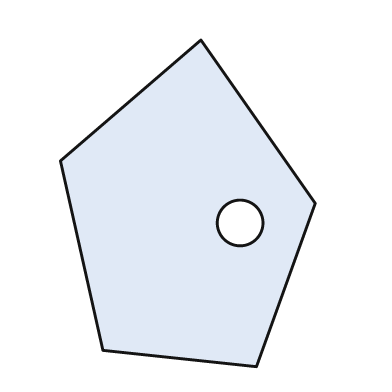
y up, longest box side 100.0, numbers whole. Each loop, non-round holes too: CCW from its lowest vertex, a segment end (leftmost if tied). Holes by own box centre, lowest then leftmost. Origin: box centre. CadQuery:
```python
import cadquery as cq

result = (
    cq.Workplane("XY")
    .moveTo(21.0, -50.0)
    .lineTo(39.0, 0.0)
    .lineTo(4.0, 50.0)
    .lineTo(-39.0, 13.0)
    .lineTo(-26.0, -45.0)
    .close()
    .moveTo(16.0, -6.0)
    .circle(7.0)
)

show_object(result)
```